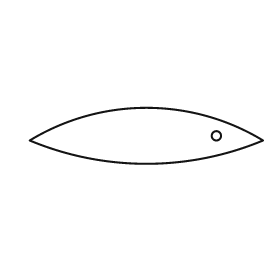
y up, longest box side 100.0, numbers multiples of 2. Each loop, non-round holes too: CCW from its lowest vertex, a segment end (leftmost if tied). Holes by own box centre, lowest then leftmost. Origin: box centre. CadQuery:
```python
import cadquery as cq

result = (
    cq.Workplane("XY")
    .moveTo(-50.0, -2.0)
    .threePointArc((0.0, -12.0), (50.0, -2.0))
    .threePointArc((0.0, 12.0), (-50.0, -2.0))
    .close()
    .moveTo(30.0, 0.0)
    .circle(2.0)
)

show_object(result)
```